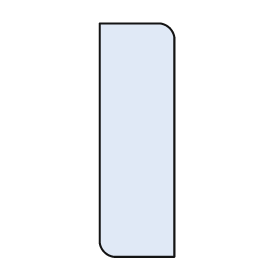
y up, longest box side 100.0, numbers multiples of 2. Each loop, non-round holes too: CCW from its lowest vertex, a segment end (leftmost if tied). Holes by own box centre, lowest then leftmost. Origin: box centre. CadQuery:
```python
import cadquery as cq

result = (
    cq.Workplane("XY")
    .moveTo(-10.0, -50.0)
    .lineTo(16.0, -50.0)
    .lineTo(16.0, 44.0)
    .threePointArc((14.0, 48.0), (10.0, 50.0))
    .lineTo(-16.0, 50.0)
    .lineTo(-16.0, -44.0)
    .threePointArc((-14.0, -48.0), (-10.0, -50.0))
    .close()
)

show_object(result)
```